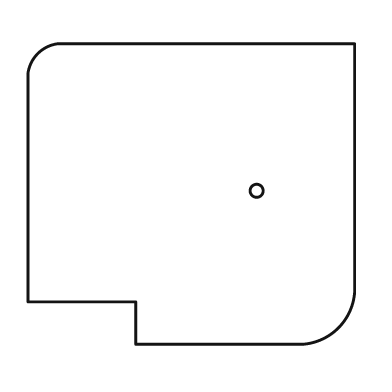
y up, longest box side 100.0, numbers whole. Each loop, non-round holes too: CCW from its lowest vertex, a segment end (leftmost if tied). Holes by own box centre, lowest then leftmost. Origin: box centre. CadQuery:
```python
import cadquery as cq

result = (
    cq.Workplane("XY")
    .moveTo(-17.0, -46.0)
    .lineTo(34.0, -46.0)
    .threePointArc((45.0, -41.0), (50.0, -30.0))
    .lineTo(50.0, 46.0)
    .lineTo(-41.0, 46.0)
    .threePointArc((-47.0, 43.0), (-50.0, 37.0))
    .lineTo(-50.0, -33.0)
    .lineTo(-17.0, -33.0)
    .close()
    .moveTo(20.0, 1.0)
    .circle(2.0)
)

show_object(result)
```